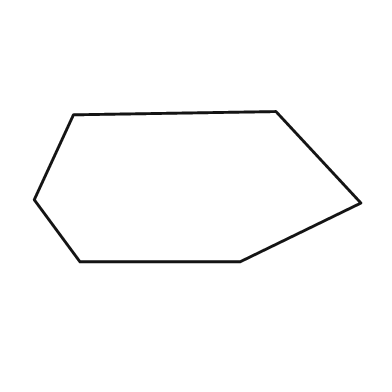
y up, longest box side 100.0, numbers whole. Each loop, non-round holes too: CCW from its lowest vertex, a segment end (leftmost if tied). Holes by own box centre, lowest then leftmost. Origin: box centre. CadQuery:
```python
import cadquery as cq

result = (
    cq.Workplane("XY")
    .moveTo(-36.0, -23.0)
    .lineTo(13.0, -23.0)
    .lineTo(50.0, -5.0)
    .lineTo(24.0, 23.0)
    .lineTo(-38.0, 22.0)
    .lineTo(-50.0, -4.0)
    .close()
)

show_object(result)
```